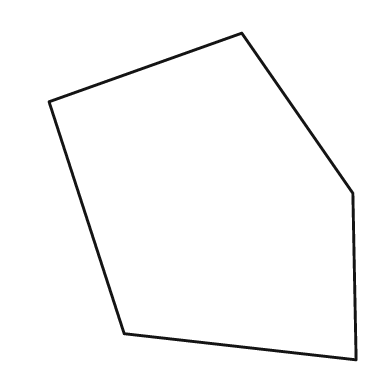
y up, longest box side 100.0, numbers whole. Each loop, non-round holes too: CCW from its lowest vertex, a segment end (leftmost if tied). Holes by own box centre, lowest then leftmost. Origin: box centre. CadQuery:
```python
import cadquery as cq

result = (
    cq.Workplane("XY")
    .moveTo(47.0, -50.0)
    .lineTo(46.0, 1.0)
    .lineTo(12.0, 50.0)
    .lineTo(-47.0, 29.0)
    .lineTo(-24.0, -42.0)
    .close()
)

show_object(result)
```